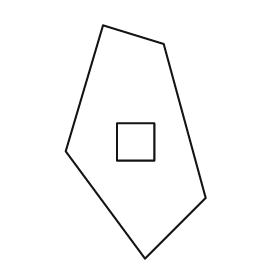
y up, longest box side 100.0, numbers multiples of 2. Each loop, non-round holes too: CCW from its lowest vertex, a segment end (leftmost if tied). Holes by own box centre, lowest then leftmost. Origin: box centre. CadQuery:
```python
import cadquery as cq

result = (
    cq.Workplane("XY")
    .moveTo(4.0, -50.0)
    .lineTo(30.0, -24.0)
    .lineTo(12.0, 42.0)
    .lineTo(-14.0, 50.0)
    .lineTo(-30.0, -4.0)
    .close()
    .moveTo(-8.0, -8.0)
    .lineTo(8.0, -8.0)
    .lineTo(8.0, 8.0)
    .lineTo(-8.0, 8.0)
    .close()
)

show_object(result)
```